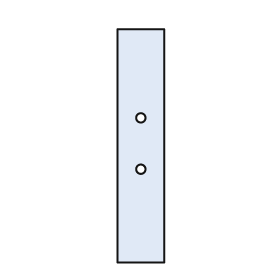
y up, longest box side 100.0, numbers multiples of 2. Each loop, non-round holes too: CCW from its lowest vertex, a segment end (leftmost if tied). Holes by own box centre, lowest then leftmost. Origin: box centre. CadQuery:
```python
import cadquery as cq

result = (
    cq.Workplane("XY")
    .moveTo(-10.0, -50.0)
    .lineTo(10.0, -50.0)
    .lineTo(10.0, 50.0)
    .lineTo(-10.0, 50.0)
    .close()
    .moveTo(0.0, -10.0)
    .circle(2.0)
    .moveTo(0.0, 12.0)
    .circle(2.0)
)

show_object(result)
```